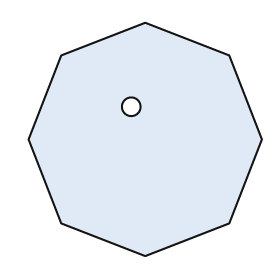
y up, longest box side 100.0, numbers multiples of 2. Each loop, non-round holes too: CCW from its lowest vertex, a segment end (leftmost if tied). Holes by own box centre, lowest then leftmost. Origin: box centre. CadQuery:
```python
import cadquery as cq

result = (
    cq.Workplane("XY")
    .moveTo(0.0, -50.0)
    .lineTo(36.0, -36.0)
    .lineTo(50.0, 0.0)
    .lineTo(36.0, 36.0)
    .lineTo(0.0, 50.0)
    .lineTo(-36.0, 36.0)
    .lineTo(-50.0, 0.0)
    .lineTo(-36.0, -36.0)
    .close()
    .moveTo(-6.0, 14.0)
    .circle(4.0)
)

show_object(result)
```